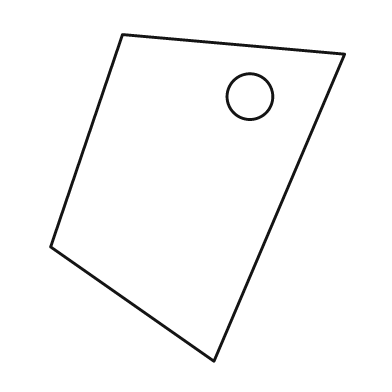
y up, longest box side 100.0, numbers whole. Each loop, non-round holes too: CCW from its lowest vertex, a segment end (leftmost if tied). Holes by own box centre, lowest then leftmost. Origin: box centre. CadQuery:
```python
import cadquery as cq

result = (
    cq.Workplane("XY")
    .moveTo(5.0, -50.0)
    .lineTo(45.0, 44.0)
    .lineTo(-23.0, 50.0)
    .lineTo(-45.0, -15.0)
    .close()
    .moveTo(16.0, 31.0)
    .circle(7.0)
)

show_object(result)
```